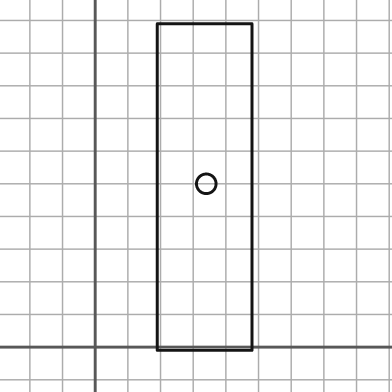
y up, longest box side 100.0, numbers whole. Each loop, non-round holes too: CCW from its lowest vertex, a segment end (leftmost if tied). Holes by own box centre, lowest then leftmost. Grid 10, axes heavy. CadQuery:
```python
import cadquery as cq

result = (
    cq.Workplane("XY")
    .moveTo(19.0, -1.0)
    .lineTo(48.0, -1.0)
    .lineTo(48.0, 99.0)
    .lineTo(19.0, 99.0)
    .close()
    .moveTo(34.0, 50.0)
    .circle(3.0)
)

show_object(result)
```